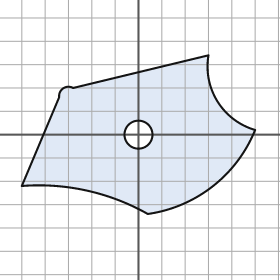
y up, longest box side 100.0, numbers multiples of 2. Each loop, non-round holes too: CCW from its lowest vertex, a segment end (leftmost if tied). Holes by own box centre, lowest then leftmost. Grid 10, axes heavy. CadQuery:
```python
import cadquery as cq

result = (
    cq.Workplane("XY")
    .moveTo(4.0, -34.0)
    .threePointArc((32.0, -22.0), (50.0, 2.0))
    .threePointArc((34.0, 14.0), (30.0, 34.0))
    .lineTo(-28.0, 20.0)
    .threePointArc((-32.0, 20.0), (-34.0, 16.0))
    .lineTo(-50.0, -22.0)
    .threePointArc((-22.0, -24.0), (4.0, -34.0))
    .close()
    .moveTo(0.0, 0.0)
    .circle(6.0)
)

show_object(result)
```